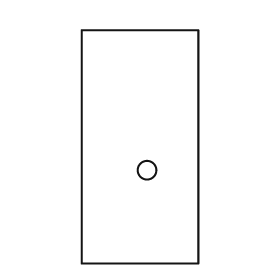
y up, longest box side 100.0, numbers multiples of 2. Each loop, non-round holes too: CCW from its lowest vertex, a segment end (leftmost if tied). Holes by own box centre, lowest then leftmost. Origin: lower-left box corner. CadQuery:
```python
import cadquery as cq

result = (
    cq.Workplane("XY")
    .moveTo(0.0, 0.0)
    .lineTo(50.0, 0.0)
    .lineTo(50.0, 100.0)
    .lineTo(0.0, 100.0)
    .close()
    .moveTo(28.0, 40.0)
    .circle(4.0)
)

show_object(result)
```